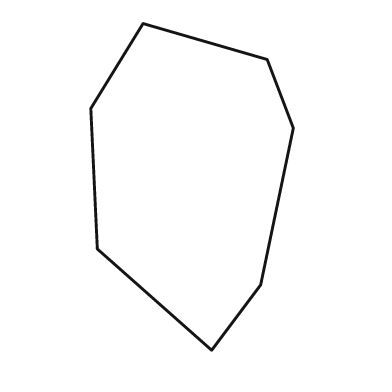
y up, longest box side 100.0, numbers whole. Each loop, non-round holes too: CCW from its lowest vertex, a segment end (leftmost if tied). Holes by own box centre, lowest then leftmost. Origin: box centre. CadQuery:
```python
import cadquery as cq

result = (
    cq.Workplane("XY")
    .moveTo(6.0, -50.0)
    .lineTo(21.0, -30.0)
    .lineTo(31.0, 18.0)
    .lineTo(23.0, 39.0)
    .lineTo(-15.0, 50.0)
    .lineTo(-31.0, 24.0)
    .lineTo(-29.0, -19.0)
    .close()
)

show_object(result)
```